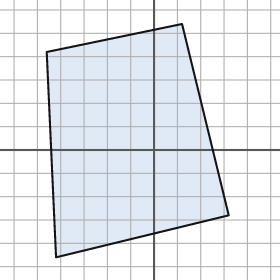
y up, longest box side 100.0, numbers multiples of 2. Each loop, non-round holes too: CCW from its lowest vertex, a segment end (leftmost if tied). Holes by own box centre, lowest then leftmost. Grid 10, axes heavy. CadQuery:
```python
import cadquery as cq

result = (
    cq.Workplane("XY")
    .moveTo(-42.0, -46.0)
    .lineTo(32.0, -28.0)
    .lineTo(12.0, 54.0)
    .lineTo(-46.0, 42.0)
    .close()
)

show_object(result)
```